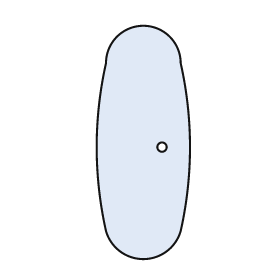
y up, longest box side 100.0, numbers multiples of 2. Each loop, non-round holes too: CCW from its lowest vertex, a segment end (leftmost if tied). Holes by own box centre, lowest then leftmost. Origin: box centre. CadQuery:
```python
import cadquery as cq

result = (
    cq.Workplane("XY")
    .moveTo(-16.0, -38.0)
    .threePointArc((0.0, -50.0), (16.0, -38.0))
    .threePointArc((20.0, -2.0), (16.0, 34.0))
    .threePointArc((0.0, 50.0), (-16.0, 34.0))
    .threePointArc((-20.0, -2.0), (-16.0, -38.0))
    .close()
    .moveTo(8.0, -2.0)
    .circle(2.0)
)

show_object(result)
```